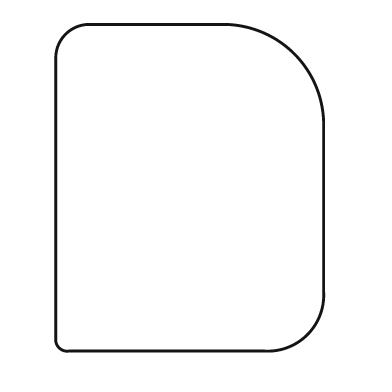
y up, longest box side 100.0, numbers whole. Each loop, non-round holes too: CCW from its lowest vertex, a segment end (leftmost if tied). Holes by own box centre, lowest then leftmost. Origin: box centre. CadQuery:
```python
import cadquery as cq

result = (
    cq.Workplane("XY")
    .moveTo(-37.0, -50.0)
    .lineTo(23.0, -50.0)
    .threePointArc((36.0, -45.0), (41.0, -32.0))
    .lineTo(41.0, 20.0)
    .threePointArc((32.0, 41.0), (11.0, 50.0))
    .lineTo(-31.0, 50.0)
    .threePointArc((-38.0, 47.0), (-41.0, 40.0))
    .lineTo(-41.0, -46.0)
    .threePointArc((-40.0, -49.0), (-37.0, -50.0))
    .close()
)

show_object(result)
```